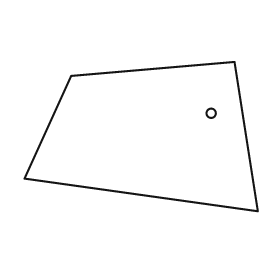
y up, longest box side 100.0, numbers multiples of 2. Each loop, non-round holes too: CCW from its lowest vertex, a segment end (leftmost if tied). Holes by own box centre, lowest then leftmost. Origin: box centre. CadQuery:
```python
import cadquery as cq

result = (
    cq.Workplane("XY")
    .moveTo(50.0, -32.0)
    .lineTo(40.0, 32.0)
    .lineTo(-30.0, 26.0)
    .lineTo(-50.0, -18.0)
    .close()
    .moveTo(30.0, 10.0)
    .circle(2.0)
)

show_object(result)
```